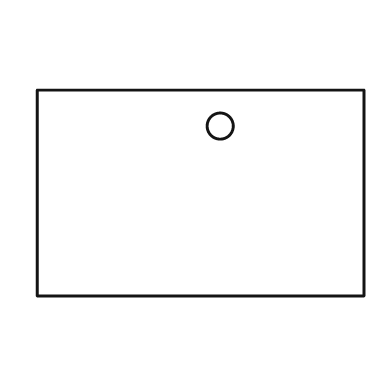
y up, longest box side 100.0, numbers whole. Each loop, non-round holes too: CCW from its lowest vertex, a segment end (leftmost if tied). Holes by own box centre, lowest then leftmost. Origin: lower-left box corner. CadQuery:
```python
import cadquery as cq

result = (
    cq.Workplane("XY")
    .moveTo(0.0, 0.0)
    .lineTo(100.0, 0.0)
    .lineTo(100.0, 63.0)
    .lineTo(0.0, 63.0)
    .close()
    .moveTo(56.0, 52.0)
    .circle(4.0)
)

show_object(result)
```